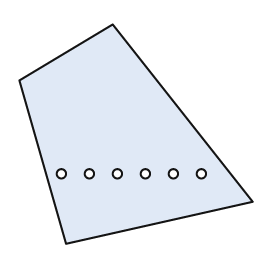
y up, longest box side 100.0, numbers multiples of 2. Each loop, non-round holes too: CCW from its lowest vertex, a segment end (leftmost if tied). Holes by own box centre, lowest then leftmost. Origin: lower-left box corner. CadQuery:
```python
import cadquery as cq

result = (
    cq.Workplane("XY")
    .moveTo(20.0, 0.0)
    .lineTo(100.0, 18.0)
    .lineTo(40.0, 94.0)
    .lineTo(0.0, 70.0)
    .close()
    .moveTo(18.0, 30.0)
    .circle(2.0)
    .moveTo(30.0, 30.0)
    .circle(2.0)
    .moveTo(42.0, 30.0)
    .circle(2.0)
    .moveTo(54.0, 30.0)
    .circle(2.0)
    .moveTo(66.0, 30.0)
    .circle(2.0)
    .moveTo(78.0, 30.0)
    .circle(2.0)
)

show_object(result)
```